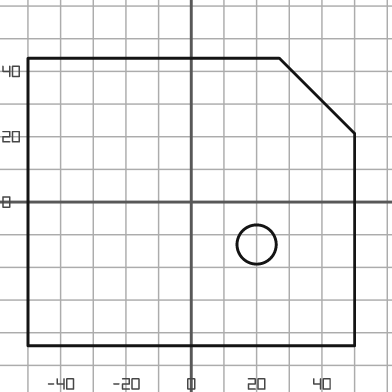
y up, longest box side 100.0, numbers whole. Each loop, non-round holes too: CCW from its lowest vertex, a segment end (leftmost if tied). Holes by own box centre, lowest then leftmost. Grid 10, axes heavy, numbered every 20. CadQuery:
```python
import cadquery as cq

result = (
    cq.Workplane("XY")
    .moveTo(-50.0, -44.0)
    .lineTo(50.0, -44.0)
    .lineTo(50.0, 21.0)
    .lineTo(27.0, 44.0)
    .lineTo(-50.0, 44.0)
    .close()
    .moveTo(20.0, -13.0)
    .circle(6.0)
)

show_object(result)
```